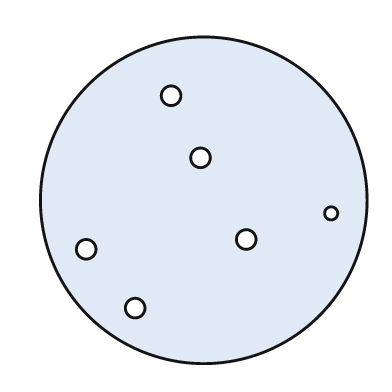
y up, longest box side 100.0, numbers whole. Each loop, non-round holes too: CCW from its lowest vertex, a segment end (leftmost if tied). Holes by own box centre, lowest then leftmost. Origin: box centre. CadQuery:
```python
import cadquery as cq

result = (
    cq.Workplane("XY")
    .moveTo(0.0, 0.0)
    .circle(50.0)
    .moveTo(-21.0, -33.0)
    .circle(3.0)
    .moveTo(-36.0, -15.0)
    .circle(3.0)
    .moveTo(13.0, -12.0)
    .circle(3.0)
    .moveTo(39.0, -4.0)
    .circle(2.0)
    .moveTo(-1.0, 13.0)
    .circle(3.0)
    .moveTo(-10.0, 32.0)
    .circle(3.0)
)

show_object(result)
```